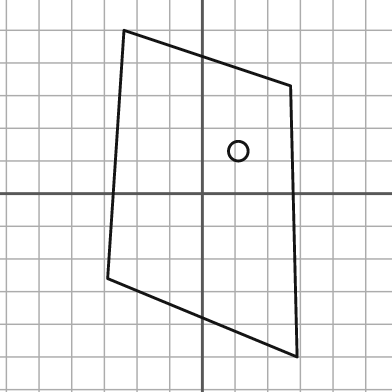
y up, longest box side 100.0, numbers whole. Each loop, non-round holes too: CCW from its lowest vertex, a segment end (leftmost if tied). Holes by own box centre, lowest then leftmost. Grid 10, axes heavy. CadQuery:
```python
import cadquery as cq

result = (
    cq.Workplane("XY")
    .moveTo(29.0, -50.0)
    .lineTo(27.0, 33.0)
    .lineTo(-24.0, 50.0)
    .lineTo(-29.0, -26.0)
    .close()
    .moveTo(11.0, 13.0)
    .circle(3.0)
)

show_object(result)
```